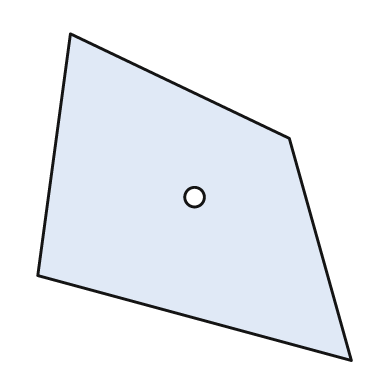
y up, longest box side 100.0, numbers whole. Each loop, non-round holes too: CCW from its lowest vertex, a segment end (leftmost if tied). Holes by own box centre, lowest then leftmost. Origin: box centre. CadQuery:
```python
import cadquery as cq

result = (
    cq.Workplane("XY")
    .moveTo(48.0, -50.0)
    .lineTo(29.0, 18.0)
    .lineTo(-38.0, 50.0)
    .lineTo(-48.0, -24.0)
    .close()
    .moveTo(0.0, 0.0)
    .circle(3.0)
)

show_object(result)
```